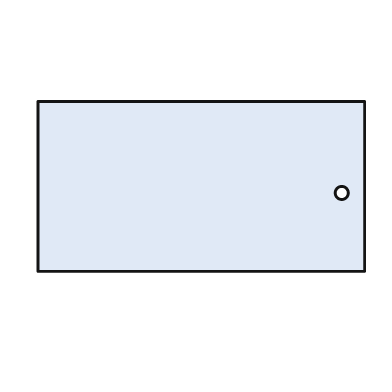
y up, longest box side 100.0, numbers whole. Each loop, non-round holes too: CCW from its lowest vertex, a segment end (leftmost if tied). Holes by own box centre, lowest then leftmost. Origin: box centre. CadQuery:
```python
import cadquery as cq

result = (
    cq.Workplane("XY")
    .moveTo(-50.0, -26.0)
    .lineTo(50.0, -26.0)
    .lineTo(50.0, 26.0)
    .lineTo(-50.0, 26.0)
    .close()
    .moveTo(43.0, -2.0)
    .circle(2.0)
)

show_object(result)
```